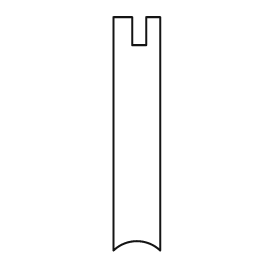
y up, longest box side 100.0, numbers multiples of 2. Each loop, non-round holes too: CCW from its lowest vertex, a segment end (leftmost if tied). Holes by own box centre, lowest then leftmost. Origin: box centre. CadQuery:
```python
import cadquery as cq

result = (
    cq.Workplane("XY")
    .moveTo(-10.0, -50.0)
    .threePointArc((0.0, -46.0), (10.0, -50.0))
    .lineTo(10.0, 50.0)
    .lineTo(4.0, 50.0)
    .lineTo(4.0, 38.0)
    .lineTo(-2.0, 38.0)
    .lineTo(-2.0, 50.0)
    .lineTo(-10.0, 50.0)
    .close()
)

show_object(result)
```